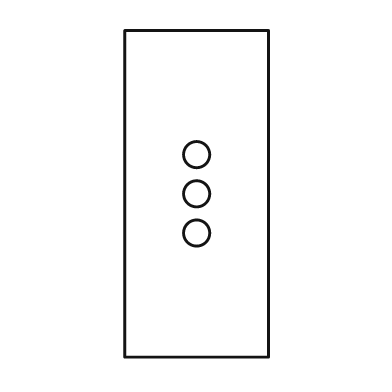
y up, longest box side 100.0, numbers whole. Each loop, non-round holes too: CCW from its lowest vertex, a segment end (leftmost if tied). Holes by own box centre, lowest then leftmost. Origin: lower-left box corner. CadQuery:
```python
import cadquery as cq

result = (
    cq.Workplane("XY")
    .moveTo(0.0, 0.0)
    .lineTo(44.0, 0.0)
    .lineTo(44.0, 100.0)
    .lineTo(0.0, 100.0)
    .close()
    .moveTo(22.0, 38.0)
    .circle(4.0)
    .moveTo(22.0, 50.0)
    .circle(4.0)
    .moveTo(22.0, 62.0)
    .circle(4.0)
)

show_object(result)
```